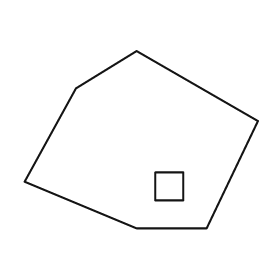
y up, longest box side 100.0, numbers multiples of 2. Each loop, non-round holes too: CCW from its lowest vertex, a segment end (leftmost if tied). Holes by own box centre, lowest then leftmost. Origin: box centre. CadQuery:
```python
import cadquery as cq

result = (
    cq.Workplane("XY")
    .moveTo(-2.0, -38.0)
    .lineTo(28.0, -38.0)
    .lineTo(50.0, 8.0)
    .lineTo(-2.0, 38.0)
    .lineTo(-28.0, 22.0)
    .lineTo(-50.0, -18.0)
    .close()
    .moveTo(6.0, -26.0)
    .lineTo(18.0, -26.0)
    .lineTo(18.0, -14.0)
    .lineTo(6.0, -14.0)
    .close()
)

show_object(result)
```